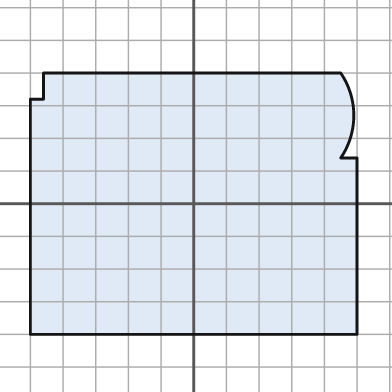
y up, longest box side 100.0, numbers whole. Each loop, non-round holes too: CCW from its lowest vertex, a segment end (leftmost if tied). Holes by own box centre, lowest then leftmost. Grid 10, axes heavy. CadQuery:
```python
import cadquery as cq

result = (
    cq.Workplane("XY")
    .moveTo(-50.0, -40.0)
    .lineTo(50.0, -40.0)
    .lineTo(50.0, 14.0)
    .lineTo(45.0, 14.0)
    .threePointArc((49.0, 27.0), (45.0, 40.0))
    .lineTo(-46.0, 40.0)
    .lineTo(-46.0, 32.0)
    .lineTo(-50.0, 32.0)
    .close()
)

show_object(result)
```